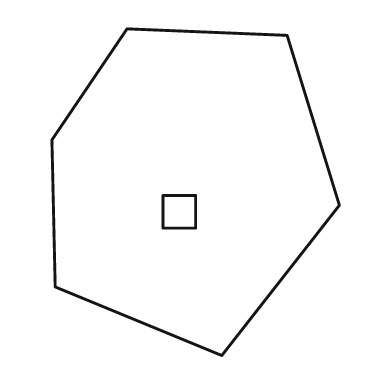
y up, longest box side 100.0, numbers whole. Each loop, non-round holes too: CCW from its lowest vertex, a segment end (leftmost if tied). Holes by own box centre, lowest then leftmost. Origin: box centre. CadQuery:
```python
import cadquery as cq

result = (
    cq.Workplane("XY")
    .moveTo(8.0, -50.0)
    .lineTo(44.0, -4.0)
    .lineTo(28.0, 48.0)
    .lineTo(-21.0, 50.0)
    .lineTo(-44.0, 16.0)
    .lineTo(-43.0, -29.0)
    .close()
    .moveTo(-10.0, -11.0)
    .lineTo(0.0, -11.0)
    .lineTo(0.0, -1.0)
    .lineTo(-10.0, -1.0)
    .close()
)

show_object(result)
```